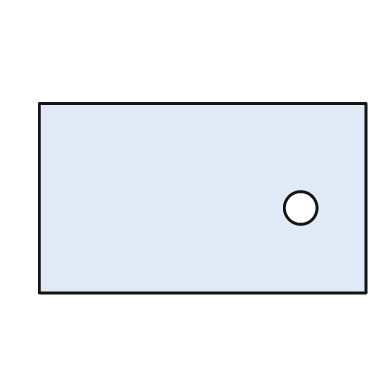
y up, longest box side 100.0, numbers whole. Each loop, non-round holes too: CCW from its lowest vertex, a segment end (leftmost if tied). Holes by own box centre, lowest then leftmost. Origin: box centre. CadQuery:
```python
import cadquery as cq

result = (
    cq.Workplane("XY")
    .moveTo(-50.0, -29.0)
    .lineTo(50.0, -29.0)
    .lineTo(50.0, 29.0)
    .lineTo(-50.0, 29.0)
    .close()
    .moveTo(30.0, -3.0)
    .circle(5.0)
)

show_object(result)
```